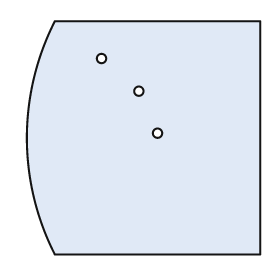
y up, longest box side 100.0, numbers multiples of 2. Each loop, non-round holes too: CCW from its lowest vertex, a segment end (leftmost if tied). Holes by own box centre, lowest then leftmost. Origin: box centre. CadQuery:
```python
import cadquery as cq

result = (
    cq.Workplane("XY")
    .moveTo(-38.0, -50.0)
    .lineTo(50.0, -50.0)
    .lineTo(50.0, 50.0)
    .lineTo(-38.0, 50.0)
    .threePointArc((-50.0, 0.0), (-38.0, -50.0))
    .close()
    .moveTo(6.0, 2.0)
    .circle(2.0)
    .moveTo(-2.0, 20.0)
    .circle(2.0)
    .moveTo(-18.0, 34.0)
    .circle(2.0)
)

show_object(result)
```